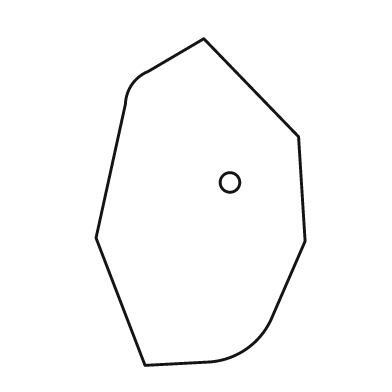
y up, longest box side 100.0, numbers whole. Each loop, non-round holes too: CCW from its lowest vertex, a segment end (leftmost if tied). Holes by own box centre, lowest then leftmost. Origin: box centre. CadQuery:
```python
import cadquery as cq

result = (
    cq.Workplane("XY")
    .moveTo(-17.0, -50.0)
    .lineTo(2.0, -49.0)
    .threePointArc((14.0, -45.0), (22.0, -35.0))
    .lineTo(32.0, -12.0)
    .lineTo(30.0, 20.0)
    .lineTo(1.0, 50.0)
    .lineTo(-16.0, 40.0)
    .threePointArc((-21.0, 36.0), (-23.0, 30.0))
    .lineTo(-32.0, -11.0)
    .close()
    .moveTo(9.0, 6.0)
    .circle(3.0)
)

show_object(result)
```